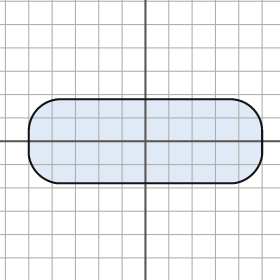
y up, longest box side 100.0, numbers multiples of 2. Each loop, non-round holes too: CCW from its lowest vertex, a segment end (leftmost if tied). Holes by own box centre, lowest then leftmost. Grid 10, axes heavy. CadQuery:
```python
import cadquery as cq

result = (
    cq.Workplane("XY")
    .moveTo(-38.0, -18.0)
    .lineTo(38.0, -18.0)
    .threePointArc((46.0, -14.0), (50.0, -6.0))
    .lineTo(50.0, 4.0)
    .threePointArc((46.0, 14.0), (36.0, 18.0))
    .lineTo(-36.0, 18.0)
    .threePointArc((-46.0, 14.0), (-50.0, 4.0))
    .lineTo(-50.0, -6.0)
    .threePointArc((-46.0, -14.0), (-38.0, -18.0))
    .close()
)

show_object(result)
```